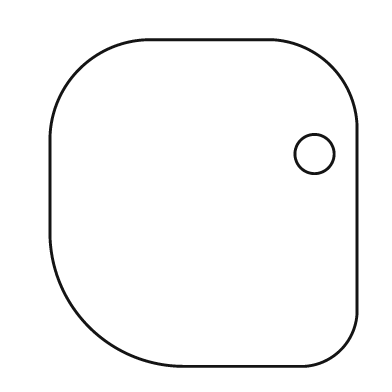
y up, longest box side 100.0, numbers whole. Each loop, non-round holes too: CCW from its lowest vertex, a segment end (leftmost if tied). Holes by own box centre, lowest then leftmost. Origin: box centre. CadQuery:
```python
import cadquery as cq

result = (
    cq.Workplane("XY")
    .moveTo(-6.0, -50.0)
    .lineTo(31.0, -50.0)
    .threePointArc((42.0, -45.0), (47.0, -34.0))
    .lineTo(47.0, 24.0)
    .threePointArc((39.0, 42.0), (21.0, 50.0))
    .lineTo(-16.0, 50.0)
    .threePointArc((-38.0, 41.0), (-47.0, 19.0))
    .lineTo(-47.0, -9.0)
    .threePointArc((-35.0, -38.0), (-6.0, -50.0))
    .close()
    .moveTo(34.0, 15.0)
    .circle(6.0)
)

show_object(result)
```